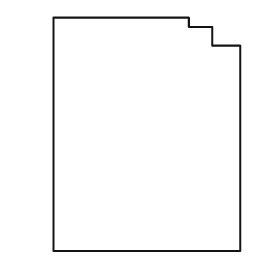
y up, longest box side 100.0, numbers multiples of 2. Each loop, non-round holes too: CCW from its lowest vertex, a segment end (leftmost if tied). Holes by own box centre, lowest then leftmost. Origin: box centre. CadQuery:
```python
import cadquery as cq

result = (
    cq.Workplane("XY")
    .moveTo(-40.0, -50.0)
    .lineTo(40.0, -50.0)
    .lineTo(40.0, 38.0)
    .lineTo(28.0, 38.0)
    .lineTo(28.0, 46.0)
    .lineTo(18.0, 46.0)
    .lineTo(18.0, 50.0)
    .lineTo(-40.0, 50.0)
    .close()
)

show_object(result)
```